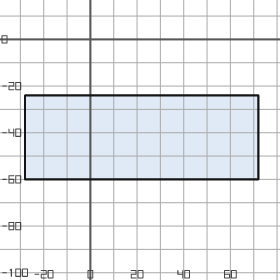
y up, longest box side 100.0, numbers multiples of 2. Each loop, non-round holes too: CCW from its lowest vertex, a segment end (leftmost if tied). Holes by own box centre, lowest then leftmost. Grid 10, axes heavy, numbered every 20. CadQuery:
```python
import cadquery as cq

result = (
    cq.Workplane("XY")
    .moveTo(-28.0, -60.0)
    .lineTo(72.0, -60.0)
    .lineTo(72.0, -24.0)
    .lineTo(-28.0, -24.0)
    .close()
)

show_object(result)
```